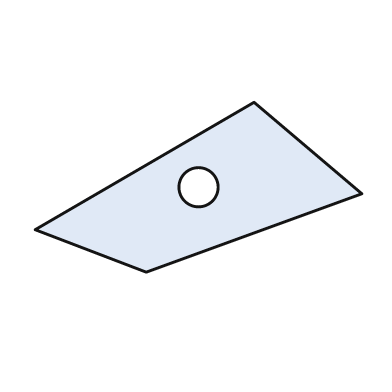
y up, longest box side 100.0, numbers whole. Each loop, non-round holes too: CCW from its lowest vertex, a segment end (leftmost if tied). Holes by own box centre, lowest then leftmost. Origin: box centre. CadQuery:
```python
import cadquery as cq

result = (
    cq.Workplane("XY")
    .moveTo(-16.0, -26.0)
    .lineTo(50.0, -2.0)
    .lineTo(17.0, 26.0)
    .lineTo(-50.0, -13.0)
    .close()
    .moveTo(0.0, 0.0)
    .circle(6.0)
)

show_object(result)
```